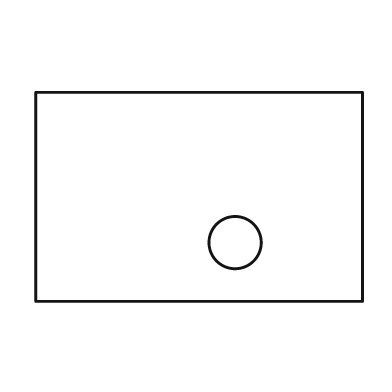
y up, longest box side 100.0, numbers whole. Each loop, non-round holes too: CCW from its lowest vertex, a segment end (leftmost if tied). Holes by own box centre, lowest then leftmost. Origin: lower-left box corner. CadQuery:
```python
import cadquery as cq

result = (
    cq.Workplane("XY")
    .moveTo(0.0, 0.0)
    .lineTo(100.0, 0.0)
    .lineTo(100.0, 64.0)
    .lineTo(0.0, 64.0)
    .close()
    .moveTo(61.0, 18.0)
    .circle(8.0)
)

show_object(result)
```